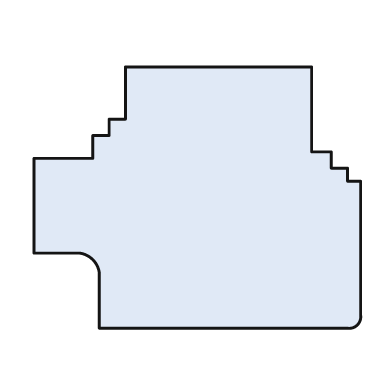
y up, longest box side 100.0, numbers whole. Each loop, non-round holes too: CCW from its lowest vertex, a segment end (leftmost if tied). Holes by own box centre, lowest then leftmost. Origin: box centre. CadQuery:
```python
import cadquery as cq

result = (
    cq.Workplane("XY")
    .moveTo(-30.0, -40.0)
    .lineTo(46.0, -40.0)
    .threePointArc((49.0, -39.0), (50.0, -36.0))
    .lineTo(50.0, 5.0)
    .lineTo(46.0, 5.0)
    .lineTo(46.0, 9.0)
    .lineTo(41.0, 9.0)
    .lineTo(41.0, 14.0)
    .lineTo(35.0, 14.0)
    .lineTo(35.0, 40.0)
    .lineTo(-22.0, 40.0)
    .lineTo(-22.0, 24.0)
    .lineTo(-27.0, 24.0)
    .lineTo(-27.0, 19.0)
    .lineTo(-32.0, 19.0)
    .lineTo(-32.0, 12.0)
    .lineTo(-50.0, 12.0)
    .lineTo(-50.0, -17.0)
    .lineTo(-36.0, -17.0)
    .threePointArc((-32.0, -19.0), (-30.0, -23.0))
    .close()
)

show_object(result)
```